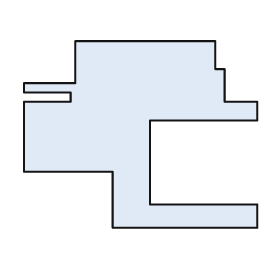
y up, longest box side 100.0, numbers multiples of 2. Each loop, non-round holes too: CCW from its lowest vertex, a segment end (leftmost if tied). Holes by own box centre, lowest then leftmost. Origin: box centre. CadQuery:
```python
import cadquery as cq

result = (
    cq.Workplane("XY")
    .moveTo(-12.0, -40.0)
    .lineTo(50.0, -40.0)
    .lineTo(50.0, -30.0)
    .lineTo(4.0, -30.0)
    .lineTo(4.0, 6.0)
    .lineTo(50.0, 6.0)
    .lineTo(50.0, 14.0)
    .lineTo(36.0, 14.0)
    .lineTo(36.0, 28.0)
    .lineTo(32.0, 28.0)
    .lineTo(32.0, 40.0)
    .lineTo(-28.0, 40.0)
    .lineTo(-28.0, 22.0)
    .lineTo(-50.0, 22.0)
    .lineTo(-50.0, 18.0)
    .lineTo(-30.0, 18.0)
    .lineTo(-30.0, 14.0)
    .lineTo(-50.0, 14.0)
    .lineTo(-50.0, -16.0)
    .lineTo(-12.0, -16.0)
    .close()
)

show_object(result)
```